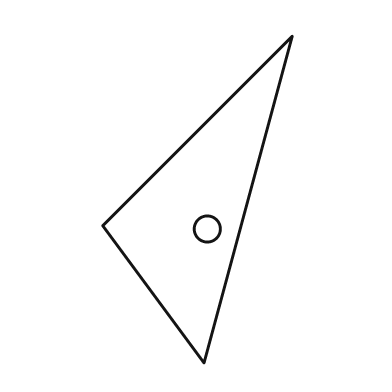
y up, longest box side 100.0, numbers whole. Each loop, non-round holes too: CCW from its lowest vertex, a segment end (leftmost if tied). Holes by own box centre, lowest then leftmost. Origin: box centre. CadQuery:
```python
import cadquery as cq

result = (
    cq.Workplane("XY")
    .moveTo(2.0, -50.0)
    .lineTo(29.0, 50.0)
    .lineTo(-29.0, -8.0)
    .close()
    .moveTo(3.0, -9.0)
    .circle(4.0)
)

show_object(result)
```